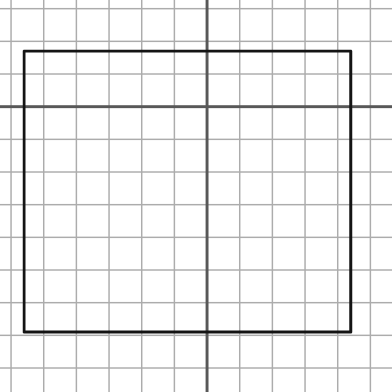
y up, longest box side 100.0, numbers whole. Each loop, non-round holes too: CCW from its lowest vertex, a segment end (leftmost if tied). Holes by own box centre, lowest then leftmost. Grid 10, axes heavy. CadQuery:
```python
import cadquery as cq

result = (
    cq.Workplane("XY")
    .moveTo(-56.0, -69.0)
    .lineTo(44.0, -69.0)
    .lineTo(44.0, 17.0)
    .lineTo(-56.0, 17.0)
    .close()
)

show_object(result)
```